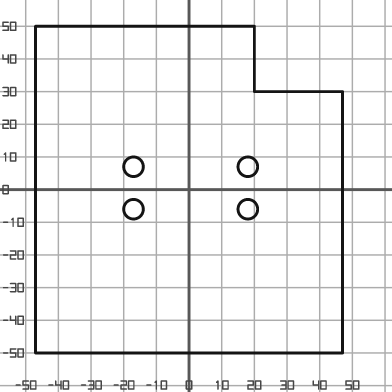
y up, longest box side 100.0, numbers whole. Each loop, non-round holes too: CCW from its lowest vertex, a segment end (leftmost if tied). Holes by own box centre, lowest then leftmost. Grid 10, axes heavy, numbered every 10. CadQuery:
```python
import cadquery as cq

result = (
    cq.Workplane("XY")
    .moveTo(-47.0, -50.0)
    .lineTo(47.0, -50.0)
    .lineTo(47.0, 30.0)
    .lineTo(20.0, 30.0)
    .lineTo(20.0, 50.0)
    .lineTo(-47.0, 50.0)
    .close()
    .moveTo(-17.0, -6.0)
    .circle(3.0)
    .moveTo(18.0, -6.0)
    .circle(3.0)
    .moveTo(-17.0, 7.0)
    .circle(3.0)
    .moveTo(18.0, 7.0)
    .circle(3.0)
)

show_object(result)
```